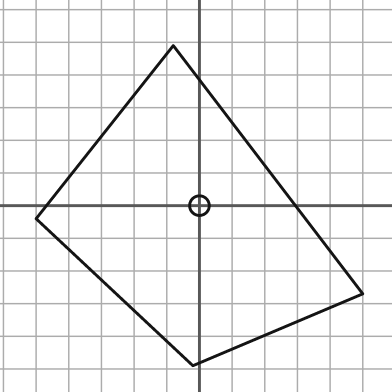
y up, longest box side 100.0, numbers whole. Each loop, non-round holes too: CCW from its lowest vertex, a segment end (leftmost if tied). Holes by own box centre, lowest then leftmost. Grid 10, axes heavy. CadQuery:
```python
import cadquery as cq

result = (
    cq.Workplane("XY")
    .moveTo(-2.0, -49.0)
    .lineTo(50.0, -27.0)
    .lineTo(-8.0, 49.0)
    .lineTo(-50.0, -4.0)
    .close()
    .moveTo(0.0, 0.0)
    .circle(3.0)
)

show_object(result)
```